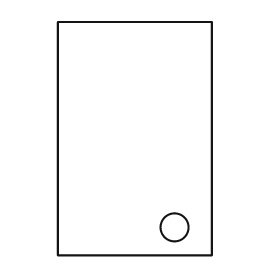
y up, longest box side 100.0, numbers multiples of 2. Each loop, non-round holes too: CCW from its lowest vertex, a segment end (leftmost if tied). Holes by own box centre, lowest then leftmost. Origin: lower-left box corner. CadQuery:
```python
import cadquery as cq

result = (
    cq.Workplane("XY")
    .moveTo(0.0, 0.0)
    .lineTo(66.0, 0.0)
    .lineTo(66.0, 100.0)
    .lineTo(0.0, 100.0)
    .close()
    .moveTo(50.0, 12.0)
    .circle(6.0)
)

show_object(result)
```